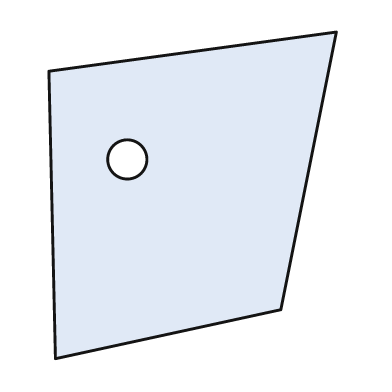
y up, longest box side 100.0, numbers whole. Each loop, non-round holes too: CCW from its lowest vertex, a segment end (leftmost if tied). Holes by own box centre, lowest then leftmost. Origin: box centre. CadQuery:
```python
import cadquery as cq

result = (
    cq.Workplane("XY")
    .moveTo(-42.0, -50.0)
    .lineTo(27.0, -35.0)
    .lineTo(44.0, 50.0)
    .lineTo(-44.0, 38.0)
    .close()
    .moveTo(-20.0, 11.0)
    .circle(6.0)
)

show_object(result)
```